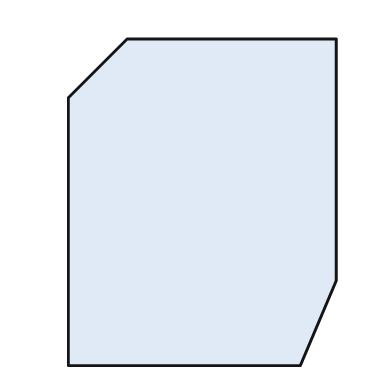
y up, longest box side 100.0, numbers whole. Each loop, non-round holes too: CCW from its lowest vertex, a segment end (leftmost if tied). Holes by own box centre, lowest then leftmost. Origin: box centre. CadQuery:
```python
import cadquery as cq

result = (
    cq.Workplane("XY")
    .moveTo(-41.0, -50.0)
    .lineTo(30.0, -50.0)
    .lineTo(41.0, -24.0)
    .lineTo(41.0, 50.0)
    .lineTo(-23.0, 50.0)
    .lineTo(-41.0, 32.0)
    .close()
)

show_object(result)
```